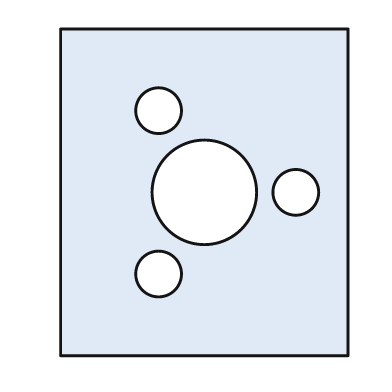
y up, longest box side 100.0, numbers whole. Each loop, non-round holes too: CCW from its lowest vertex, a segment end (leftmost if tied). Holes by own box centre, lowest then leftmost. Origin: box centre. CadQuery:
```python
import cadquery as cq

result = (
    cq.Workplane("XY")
    .moveTo(-44.0, -50.0)
    .lineTo(44.0, -50.0)
    .lineTo(44.0, 50.0)
    .lineTo(-44.0, 50.0)
    .close()
    .moveTo(-14.0, -25.0)
    .circle(7.0)
    .moveTo(0.0, 0.0)
    .circle(16.0)
    .moveTo(28.0, 0.0)
    .circle(7.0)
    .moveTo(-14.0, 25.0)
    .circle(7.0)
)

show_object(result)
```